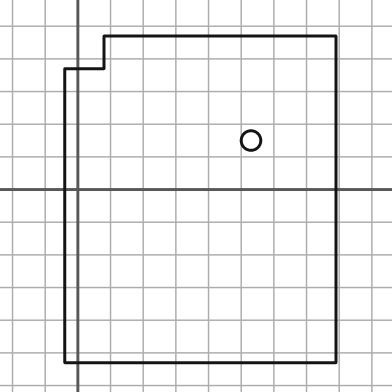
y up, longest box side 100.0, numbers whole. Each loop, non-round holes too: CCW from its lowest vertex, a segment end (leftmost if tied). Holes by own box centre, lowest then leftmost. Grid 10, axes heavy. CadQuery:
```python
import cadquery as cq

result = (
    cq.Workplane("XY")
    .moveTo(-4.0, -53.0)
    .lineTo(79.0, -53.0)
    .lineTo(79.0, 47.0)
    .lineTo(8.0, 47.0)
    .lineTo(8.0, 37.0)
    .lineTo(-4.0, 37.0)
    .close()
    .moveTo(53.0, 15.0)
    .circle(3.0)
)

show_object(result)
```